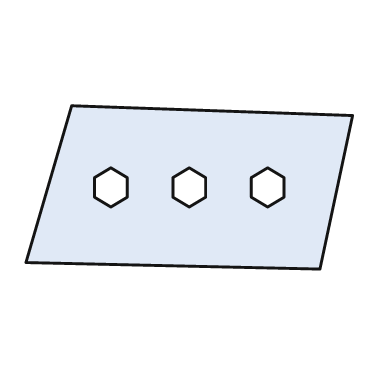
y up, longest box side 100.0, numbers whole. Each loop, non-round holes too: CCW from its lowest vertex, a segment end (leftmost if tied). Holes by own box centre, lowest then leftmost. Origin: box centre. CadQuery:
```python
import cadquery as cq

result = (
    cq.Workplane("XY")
    .moveTo(40.0, -25.0)
    .lineTo(50.0, 22.0)
    .lineTo(-36.0, 25.0)
    .lineTo(-50.0, -23.0)
    .close()
    .moveTo(-24.0, -6.0)
    .lineTo(-19.0, -3.0)
    .lineTo(-19.0, 3.0)
    .lineTo(-24.0, 6.0)
    .lineTo(-29.0, 3.0)
    .lineTo(-29.0, -3.0)
    .close()
    .moveTo(0.0, -6.0)
    .lineTo(5.0, -3.0)
    .lineTo(5.0, 3.0)
    .lineTo(0.0, 6.0)
    .lineTo(-5.0, 3.0)
    .lineTo(-5.0, -3.0)
    .close()
    .moveTo(24.0, -6.0)
    .lineTo(29.0, -3.0)
    .lineTo(29.0, 3.0)
    .lineTo(24.0, 6.0)
    .lineTo(19.0, 3.0)
    .lineTo(19.0, -3.0)
    .close()
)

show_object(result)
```